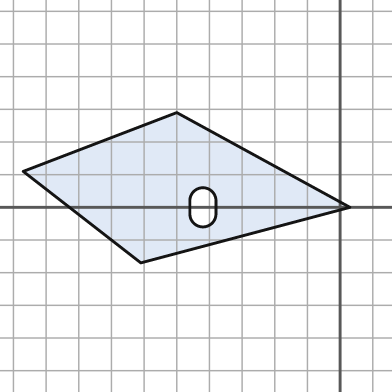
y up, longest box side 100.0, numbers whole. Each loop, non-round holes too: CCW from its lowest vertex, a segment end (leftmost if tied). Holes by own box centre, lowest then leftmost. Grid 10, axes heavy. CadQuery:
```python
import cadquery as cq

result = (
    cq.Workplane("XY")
    .moveTo(-61.0, -17.0)
    .lineTo(3.0, 0.0)
    .lineTo(-50.0, 29.0)
    .lineTo(-97.0, 11.0)
    .close()
    .moveTo(-46.0, -2.0)
    .threePointArc((-42.0, -6.0), (-38.0, -2.0))
    .lineTo(-38.0, 2.0)
    .threePointArc((-42.0, 6.0), (-46.0, 2.0))
    .close()
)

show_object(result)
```